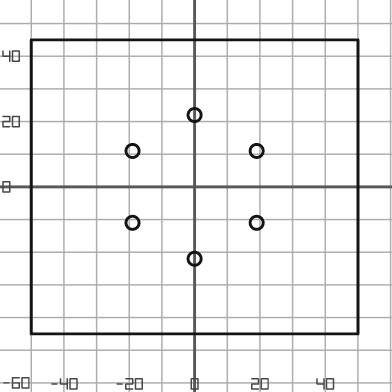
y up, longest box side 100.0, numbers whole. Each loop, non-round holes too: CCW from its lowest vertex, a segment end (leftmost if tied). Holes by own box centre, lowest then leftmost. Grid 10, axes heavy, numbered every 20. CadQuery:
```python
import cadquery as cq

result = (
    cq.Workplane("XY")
    .moveTo(-50.0, -45.0)
    .lineTo(50.0, -45.0)
    .lineTo(50.0, 45.0)
    .lineTo(-50.0, 45.0)
    .close()
    .moveTo(0.0, -22.0)
    .circle(2.0)
    .moveTo(-19.0, -11.0)
    .circle(2.0)
    .moveTo(19.0, -11.0)
    .circle(2.0)
    .moveTo(-19.0, 11.0)
    .circle(2.0)
    .moveTo(19.0, 11.0)
    .circle(2.0)
    .moveTo(0.0, 22.0)
    .circle(2.0)
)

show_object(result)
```